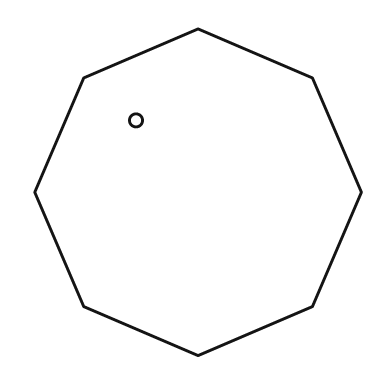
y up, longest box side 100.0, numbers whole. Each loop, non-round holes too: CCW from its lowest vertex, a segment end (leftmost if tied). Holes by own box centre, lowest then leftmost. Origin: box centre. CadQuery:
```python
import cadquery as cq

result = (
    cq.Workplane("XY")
    .moveTo(0.0, -50.0)
    .lineTo(35.0, -35.0)
    .lineTo(50.0, 0.0)
    .lineTo(35.0, 35.0)
    .lineTo(0.0, 50.0)
    .lineTo(-35.0, 35.0)
    .lineTo(-50.0, 0.0)
    .lineTo(-35.0, -35.0)
    .close()
    .moveTo(-19.0, 22.0)
    .circle(2.0)
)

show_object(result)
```